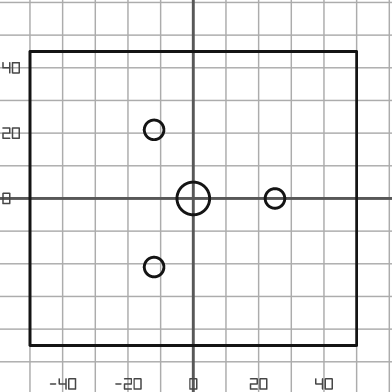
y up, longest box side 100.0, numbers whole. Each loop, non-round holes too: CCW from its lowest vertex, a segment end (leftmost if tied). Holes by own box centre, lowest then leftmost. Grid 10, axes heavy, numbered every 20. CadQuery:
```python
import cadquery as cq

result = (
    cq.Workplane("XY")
    .moveTo(-50.0, -45.0)
    .lineTo(50.0, -45.0)
    .lineTo(50.0, 45.0)
    .lineTo(-50.0, 45.0)
    .close()
    .moveTo(-12.0, -21.0)
    .circle(3.0)
    .moveTo(0.0, 0.0)
    .circle(5.0)
    .moveTo(25.0, 0.0)
    .circle(3.0)
    .moveTo(-12.0, 21.0)
    .circle(3.0)
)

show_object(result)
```